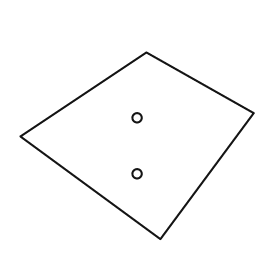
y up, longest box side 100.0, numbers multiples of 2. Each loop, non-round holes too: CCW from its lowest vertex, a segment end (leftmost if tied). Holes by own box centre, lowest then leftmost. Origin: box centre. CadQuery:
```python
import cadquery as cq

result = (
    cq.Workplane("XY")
    .moveTo(10.0, -40.0)
    .lineTo(50.0, 14.0)
    .lineTo(4.0, 40.0)
    .lineTo(-50.0, 4.0)
    .close()
    .moveTo(0.0, -12.0)
    .circle(2.0)
    .moveTo(0.0, 12.0)
    .circle(2.0)
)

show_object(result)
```